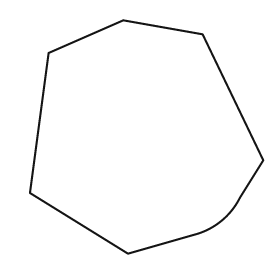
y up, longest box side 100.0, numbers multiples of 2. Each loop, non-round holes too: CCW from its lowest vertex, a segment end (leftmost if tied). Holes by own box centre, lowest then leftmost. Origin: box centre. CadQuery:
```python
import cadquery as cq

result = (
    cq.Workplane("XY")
    .moveTo(-8.0, -50.0)
    .lineTo(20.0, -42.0)
    .threePointArc((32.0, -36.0), (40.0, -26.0))
    .lineTo(50.0, -10.0)
    .lineTo(24.0, 44.0)
    .lineTo(-10.0, 50.0)
    .lineTo(-42.0, 36.0)
    .lineTo(-50.0, -24.0)
    .close()
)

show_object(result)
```